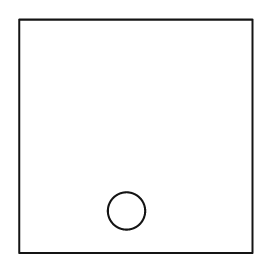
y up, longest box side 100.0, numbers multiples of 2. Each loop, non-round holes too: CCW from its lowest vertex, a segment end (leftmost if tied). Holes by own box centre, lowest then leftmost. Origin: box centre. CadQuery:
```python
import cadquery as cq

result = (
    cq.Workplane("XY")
    .moveTo(-50.0, -50.0)
    .lineTo(50.0, -50.0)
    .lineTo(50.0, 50.0)
    .lineTo(-50.0, 50.0)
    .close()
    .moveTo(-4.0, -32.0)
    .circle(8.0)
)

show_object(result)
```